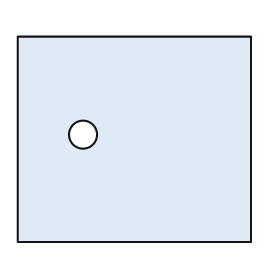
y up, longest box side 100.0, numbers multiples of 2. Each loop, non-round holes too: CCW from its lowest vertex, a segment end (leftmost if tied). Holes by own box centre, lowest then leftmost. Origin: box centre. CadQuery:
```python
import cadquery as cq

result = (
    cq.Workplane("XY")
    .moveTo(-50.0, -44.0)
    .lineTo(50.0, -44.0)
    .lineTo(50.0, 44.0)
    .lineTo(-50.0, 44.0)
    .close()
    .moveTo(-22.0, 2.0)
    .circle(6.0)
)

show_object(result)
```